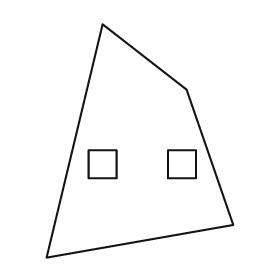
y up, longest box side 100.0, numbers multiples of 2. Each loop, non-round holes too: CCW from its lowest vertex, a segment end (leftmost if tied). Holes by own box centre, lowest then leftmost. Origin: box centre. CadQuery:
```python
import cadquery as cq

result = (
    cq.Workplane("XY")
    .moveTo(-40.0, -50.0)
    .lineTo(40.0, -36.0)
    .lineTo(20.0, 22.0)
    .lineTo(-16.0, 50.0)
    .close()
    .moveTo(-22.0, -16.0)
    .lineTo(-10.0, -16.0)
    .lineTo(-10.0, -4.0)
    .lineTo(-22.0, -4.0)
    .close()
    .moveTo(12.0, -16.0)
    .lineTo(24.0, -16.0)
    .lineTo(24.0, -4.0)
    .lineTo(12.0, -4.0)
    .close()
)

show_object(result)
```